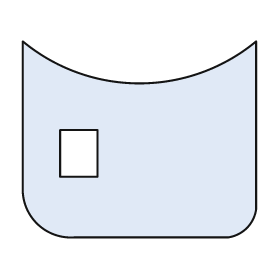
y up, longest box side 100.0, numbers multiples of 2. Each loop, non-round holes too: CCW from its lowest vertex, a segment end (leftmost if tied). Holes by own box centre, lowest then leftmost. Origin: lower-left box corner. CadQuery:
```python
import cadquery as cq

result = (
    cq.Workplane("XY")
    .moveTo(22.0, 0.0)
    .lineTo(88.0, 0.0)
    .threePointArc((96.0, 4.0), (100.0, 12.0))
    .lineTo(100.0, 84.0)
    .threePointArc((50.0, 66.0), (0.0, 84.0))
    .lineTo(0.0, 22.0)
    .threePointArc((6.0, 6.0), (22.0, 0.0))
    .close()
    .moveTo(16.0, 26.0)
    .lineTo(32.0, 26.0)
    .lineTo(32.0, 46.0)
    .lineTo(16.0, 46.0)
    .close()
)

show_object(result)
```